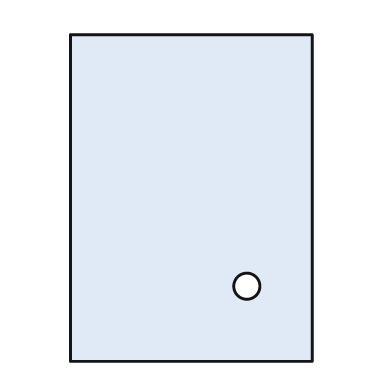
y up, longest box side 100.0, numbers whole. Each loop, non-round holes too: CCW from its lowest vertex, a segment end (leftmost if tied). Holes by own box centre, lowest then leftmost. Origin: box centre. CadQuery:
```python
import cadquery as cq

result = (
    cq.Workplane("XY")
    .moveTo(-37.0, -50.0)
    .lineTo(37.0, -50.0)
    .lineTo(37.0, 50.0)
    .lineTo(-37.0, 50.0)
    .close()
    .moveTo(17.0, -27.0)
    .circle(4.0)
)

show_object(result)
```